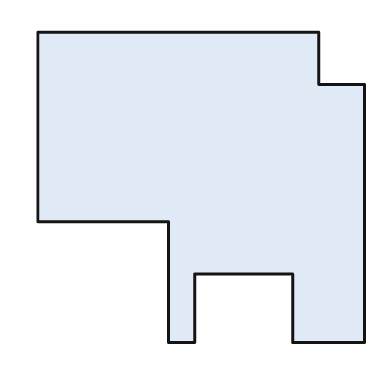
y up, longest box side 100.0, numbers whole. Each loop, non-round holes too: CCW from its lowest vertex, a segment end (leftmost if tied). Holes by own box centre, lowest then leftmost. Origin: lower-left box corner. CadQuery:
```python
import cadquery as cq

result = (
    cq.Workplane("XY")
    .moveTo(40.0, 0.0)
    .lineTo(48.0, 0.0)
    .lineTo(48.0, 21.0)
    .lineTo(78.0, 21.0)
    .lineTo(78.0, 0.0)
    .lineTo(100.0, 0.0)
    .lineTo(100.0, 79.0)
    .lineTo(86.0, 79.0)
    .lineTo(86.0, 95.0)
    .lineTo(0.0, 95.0)
    .lineTo(0.0, 37.0)
    .lineTo(40.0, 37.0)
    .close()
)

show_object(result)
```